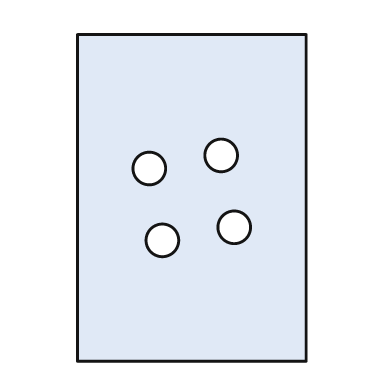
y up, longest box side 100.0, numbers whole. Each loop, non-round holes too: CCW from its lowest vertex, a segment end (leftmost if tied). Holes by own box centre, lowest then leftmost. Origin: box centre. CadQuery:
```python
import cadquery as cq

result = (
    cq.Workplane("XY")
    .moveTo(-35.0, -50.0)
    .lineTo(35.0, -50.0)
    .lineTo(35.0, 50.0)
    .lineTo(-35.0, 50.0)
    .close()
    .moveTo(-9.0, -13.0)
    .circle(5.0)
    .moveTo(13.0, -9.0)
    .circle(5.0)
    .moveTo(-13.0, 9.0)
    .circle(5.0)
    .moveTo(9.0, 13.0)
    .circle(5.0)
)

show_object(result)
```